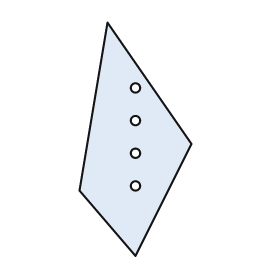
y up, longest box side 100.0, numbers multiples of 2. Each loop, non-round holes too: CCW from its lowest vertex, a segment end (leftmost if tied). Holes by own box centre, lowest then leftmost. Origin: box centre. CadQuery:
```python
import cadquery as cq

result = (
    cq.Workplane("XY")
    .moveTo(0.0, -50.0)
    .lineTo(24.0, -2.0)
    .lineTo(-12.0, 50.0)
    .lineTo(-24.0, -22.0)
    .close()
    .moveTo(0.0, -20.0)
    .circle(2.0)
    .moveTo(0.0, -6.0)
    .circle(2.0)
    .moveTo(0.0, 8.0)
    .circle(2.0)
    .moveTo(0.0, 22.0)
    .circle(2.0)
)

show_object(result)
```